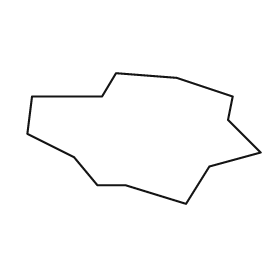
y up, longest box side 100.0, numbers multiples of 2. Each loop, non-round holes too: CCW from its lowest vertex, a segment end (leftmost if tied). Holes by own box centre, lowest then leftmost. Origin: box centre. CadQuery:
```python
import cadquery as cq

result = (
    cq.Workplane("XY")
    .moveTo(18.0, -28.0)
    .lineTo(28.0, -12.0)
    .lineTo(50.0, -6.0)
    .lineTo(36.0, 8.0)
    .lineTo(38.0, 18.0)
    .lineTo(14.0, 26.0)
    .lineTo(-12.0, 28.0)
    .lineTo(-18.0, 18.0)
    .lineTo(-48.0, 18.0)
    .lineTo(-50.0, 2.0)
    .lineTo(-30.0, -8.0)
    .lineTo(-20.0, -20.0)
    .lineTo(-8.0, -20.0)
    .close()
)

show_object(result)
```